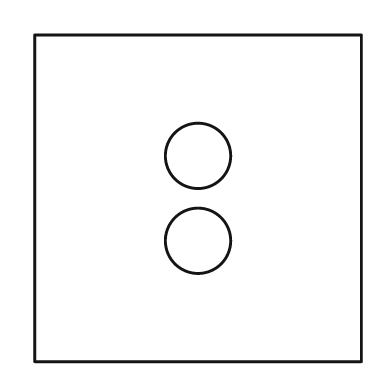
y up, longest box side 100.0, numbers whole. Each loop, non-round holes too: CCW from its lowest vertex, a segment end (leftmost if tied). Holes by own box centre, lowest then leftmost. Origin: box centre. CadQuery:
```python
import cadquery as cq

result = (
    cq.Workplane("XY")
    .moveTo(-50.0, -50.0)
    .lineTo(50.0, -50.0)
    .lineTo(50.0, 50.0)
    .lineTo(-50.0, 50.0)
    .close()
    .moveTo(0.0, -13.0)
    .circle(10.0)
    .moveTo(0.0, 13.0)
    .circle(10.0)
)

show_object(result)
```